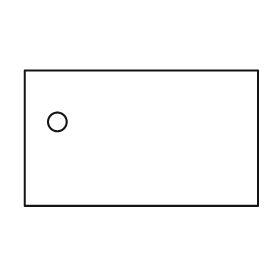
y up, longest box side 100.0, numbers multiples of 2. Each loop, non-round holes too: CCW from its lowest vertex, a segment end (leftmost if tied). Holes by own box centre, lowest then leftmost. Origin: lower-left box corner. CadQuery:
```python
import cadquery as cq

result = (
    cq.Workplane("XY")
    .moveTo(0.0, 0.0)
    .lineTo(100.0, 0.0)
    .lineTo(100.0, 58.0)
    .lineTo(0.0, 58.0)
    .close()
    .moveTo(14.0, 36.0)
    .circle(4.0)
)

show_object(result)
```